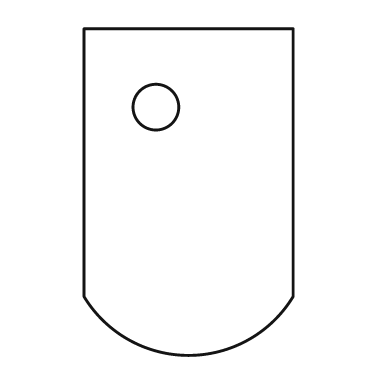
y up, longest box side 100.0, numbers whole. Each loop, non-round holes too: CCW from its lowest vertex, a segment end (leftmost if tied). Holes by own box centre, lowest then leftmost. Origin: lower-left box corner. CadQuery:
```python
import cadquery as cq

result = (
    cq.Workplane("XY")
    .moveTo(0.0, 18.0)
    .threePointArc((32.0, 0.0), (64.0, 18.0))
    .lineTo(64.0, 100.0)
    .lineTo(0.0, 100.0)
    .close()
    .moveTo(22.0, 76.0)
    .circle(7.0)
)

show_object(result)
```